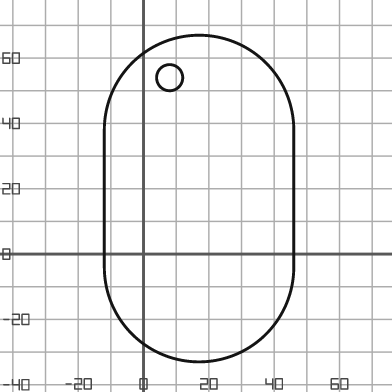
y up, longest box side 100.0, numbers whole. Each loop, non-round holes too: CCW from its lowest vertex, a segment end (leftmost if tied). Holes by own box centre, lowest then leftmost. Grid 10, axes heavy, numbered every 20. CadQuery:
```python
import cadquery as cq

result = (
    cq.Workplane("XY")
    .moveTo(-12.0, -4.0)
    .threePointArc((17.0, -33.0), (46.0, -4.0))
    .lineTo(46.0, 38.0)
    .threePointArc((17.0, 67.0), (-12.0, 38.0))
    .close()
    .moveTo(8.0, 54.0)
    .circle(4.0)
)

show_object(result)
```